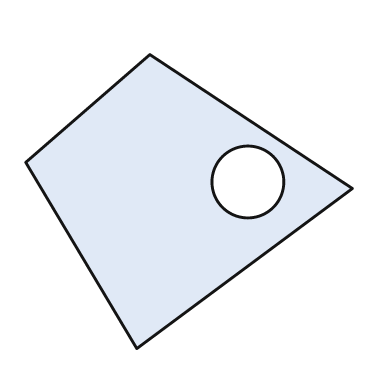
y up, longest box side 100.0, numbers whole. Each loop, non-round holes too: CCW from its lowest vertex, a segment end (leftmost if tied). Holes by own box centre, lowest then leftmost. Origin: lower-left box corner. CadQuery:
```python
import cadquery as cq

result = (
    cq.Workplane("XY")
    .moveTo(34.0, 0.0)
    .lineTo(100.0, 49.0)
    .lineTo(38.0, 90.0)
    .lineTo(0.0, 57.0)
    .close()
    .moveTo(68.0, 51.0)
    .circle(11.0)
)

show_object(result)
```